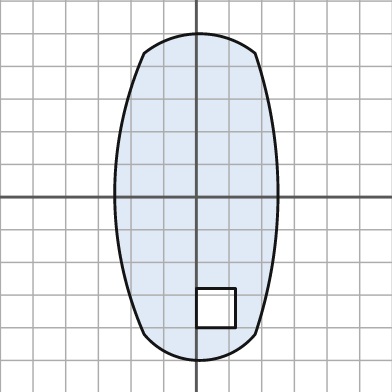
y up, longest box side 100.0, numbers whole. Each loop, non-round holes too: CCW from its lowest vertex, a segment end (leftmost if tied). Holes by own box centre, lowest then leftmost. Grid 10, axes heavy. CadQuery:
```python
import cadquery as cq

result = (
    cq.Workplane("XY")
    .moveTo(-16.0, -42.0)
    .threePointArc((1.0, -50.0), (18.0, -42.0))
    .threePointArc((25.0, 1.0), (18.0, 44.0))
    .threePointArc((1.0, 50.0), (-16.0, 44.0))
    .threePointArc((-25.0, 1.0), (-16.0, -42.0))
    .close()
    .moveTo(0.0, -40.0)
    .lineTo(12.0, -40.0)
    .lineTo(12.0, -28.0)
    .lineTo(0.0, -28.0)
    .close()
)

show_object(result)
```